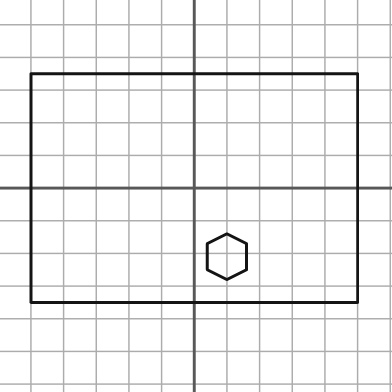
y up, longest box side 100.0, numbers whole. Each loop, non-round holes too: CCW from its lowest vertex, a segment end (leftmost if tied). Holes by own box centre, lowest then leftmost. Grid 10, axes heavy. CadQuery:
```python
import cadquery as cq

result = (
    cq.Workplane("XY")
    .moveTo(-50.0, -35.0)
    .lineTo(50.0, -35.0)
    .lineTo(50.0, 35.0)
    .lineTo(-50.0, 35.0)
    .close()
    .moveTo(10.0, -28.0)
    .lineTo(16.0, -25.0)
    .lineTo(16.0, -17.0)
    .lineTo(10.0, -14.0)
    .lineTo(4.0, -17.0)
    .lineTo(4.0, -25.0)
    .close()
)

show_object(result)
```